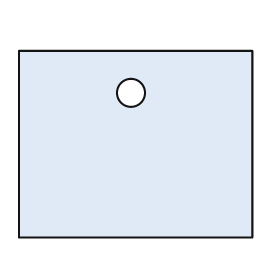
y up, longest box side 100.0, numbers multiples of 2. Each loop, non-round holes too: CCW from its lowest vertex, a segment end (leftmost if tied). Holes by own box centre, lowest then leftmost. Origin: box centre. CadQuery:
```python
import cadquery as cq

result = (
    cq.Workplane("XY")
    .moveTo(-50.0, -40.0)
    .lineTo(50.0, -40.0)
    .lineTo(50.0, 40.0)
    .lineTo(-50.0, 40.0)
    .close()
    .moveTo(-2.0, 22.0)
    .circle(6.0)
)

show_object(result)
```